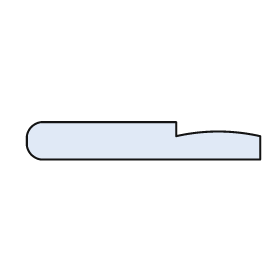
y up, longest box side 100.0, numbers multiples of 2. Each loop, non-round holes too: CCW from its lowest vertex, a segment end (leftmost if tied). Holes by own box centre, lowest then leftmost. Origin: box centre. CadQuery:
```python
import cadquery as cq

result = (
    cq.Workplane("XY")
    .moveTo(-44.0, -8.0)
    .lineTo(50.0, -8.0)
    .lineTo(50.0, 2.0)
    .threePointArc((32.0, 4.0), (14.0, 2.0))
    .lineTo(14.0, 8.0)
    .lineTo(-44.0, 8.0)
    .threePointArc((-48.0, 6.0), (-50.0, 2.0))
    .lineTo(-50.0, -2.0)
    .threePointArc((-48.0, -6.0), (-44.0, -8.0))
    .close()
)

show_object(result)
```